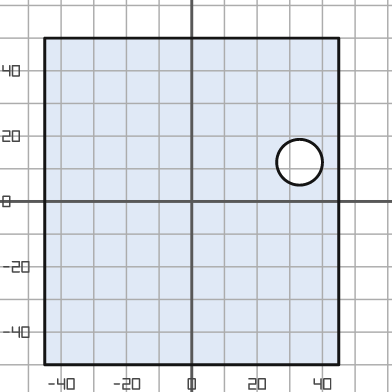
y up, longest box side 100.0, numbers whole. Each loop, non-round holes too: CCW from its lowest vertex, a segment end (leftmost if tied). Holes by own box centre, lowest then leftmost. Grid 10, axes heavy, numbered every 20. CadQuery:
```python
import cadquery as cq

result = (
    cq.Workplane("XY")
    .moveTo(-45.0, -50.0)
    .lineTo(45.0, -50.0)
    .lineTo(45.0, 50.0)
    .lineTo(-45.0, 50.0)
    .close()
    .moveTo(33.0, 12.0)
    .circle(7.0)
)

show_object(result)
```